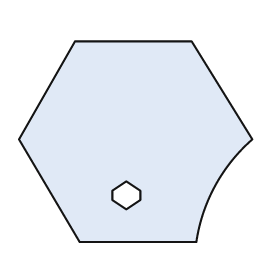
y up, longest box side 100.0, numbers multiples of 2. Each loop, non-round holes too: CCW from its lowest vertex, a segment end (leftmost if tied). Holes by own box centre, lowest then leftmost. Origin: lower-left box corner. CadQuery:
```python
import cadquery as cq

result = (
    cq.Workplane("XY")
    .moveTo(26.0, 0.0)
    .lineTo(76.0, 0.0)
    .threePointArc((84.0, 24.0), (100.0, 44.0))
    .lineTo(74.0, 86.0)
    .lineTo(24.0, 86.0)
    .lineTo(0.0, 44.0)
    .close()
    .moveTo(46.0, 14.0)
    .lineTo(52.0, 18.0)
    .lineTo(52.0, 22.0)
    .lineTo(46.0, 26.0)
    .lineTo(40.0, 22.0)
    .lineTo(40.0, 18.0)
    .close()
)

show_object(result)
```